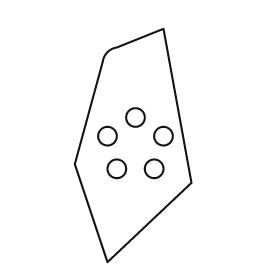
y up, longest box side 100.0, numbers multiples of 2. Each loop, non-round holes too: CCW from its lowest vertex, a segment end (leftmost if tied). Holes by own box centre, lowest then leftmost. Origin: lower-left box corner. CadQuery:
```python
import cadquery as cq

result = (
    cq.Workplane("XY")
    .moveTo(14.0, 0.0)
    .lineTo(50.0, 34.0)
    .lineTo(38.0, 100.0)
    .lineTo(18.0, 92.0)
    .threePointArc((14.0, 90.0), (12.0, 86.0))
    .lineTo(0.0, 42.0)
    .close()
    .moveTo(18.0, 40.0)
    .circle(4.0)
    .moveTo(34.0, 40.0)
    .circle(4.0)
    .moveTo(14.0, 54.0)
    .circle(4.0)
    .moveTo(38.0, 54.0)
    .circle(4.0)
    .moveTo(26.0, 62.0)
    .circle(4.0)
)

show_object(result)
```